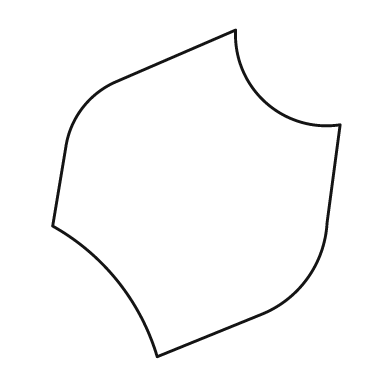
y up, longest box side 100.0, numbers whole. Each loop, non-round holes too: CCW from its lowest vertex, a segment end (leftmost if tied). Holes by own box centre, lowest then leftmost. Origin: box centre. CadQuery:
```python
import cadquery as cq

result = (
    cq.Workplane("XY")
    .moveTo(-12.0, -50.0)
    .lineTo(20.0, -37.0)
    .threePointArc((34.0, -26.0), (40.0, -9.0))
    .lineTo(44.0, 21.0)
    .threePointArc((21.0, 28.0), (12.0, 50.0))
    .lineTo(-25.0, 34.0)
    .threePointArc((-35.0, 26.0), (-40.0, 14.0))
    .lineTo(-44.0, -10.0)
    .threePointArc((-24.0, -27.0), (-12.0, -50.0))
    .close()
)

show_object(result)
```